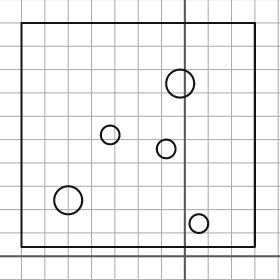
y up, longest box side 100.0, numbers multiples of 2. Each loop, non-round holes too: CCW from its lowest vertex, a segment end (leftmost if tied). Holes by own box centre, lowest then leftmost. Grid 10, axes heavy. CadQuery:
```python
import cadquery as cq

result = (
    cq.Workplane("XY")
    .moveTo(-70.0, 4.0)
    .lineTo(30.0, 4.0)
    .lineTo(30.0, 100.0)
    .lineTo(-70.0, 100.0)
    .close()
    .moveTo(6.0, 14.0)
    .circle(4.0)
    .moveTo(-50.0, 24.0)
    .circle(6.0)
    .moveTo(-8.0, 46.0)
    .circle(4.0)
    .moveTo(-32.0, 52.0)
    .circle(4.0)
    .moveTo(-2.0, 74.0)
    .circle(6.0)
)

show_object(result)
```